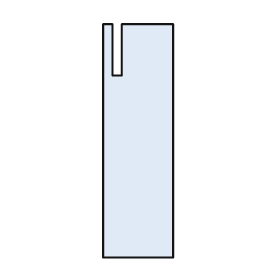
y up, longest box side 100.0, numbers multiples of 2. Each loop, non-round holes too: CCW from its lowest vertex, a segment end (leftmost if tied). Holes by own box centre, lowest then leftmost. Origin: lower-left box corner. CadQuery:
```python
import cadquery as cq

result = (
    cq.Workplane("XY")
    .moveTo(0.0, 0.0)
    .lineTo(30.0, 0.0)
    .lineTo(30.0, 100.0)
    .lineTo(8.0, 100.0)
    .lineTo(8.0, 78.0)
    .lineTo(4.0, 78.0)
    .lineTo(4.0, 100.0)
    .lineTo(0.0, 100.0)
    .close()
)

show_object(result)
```